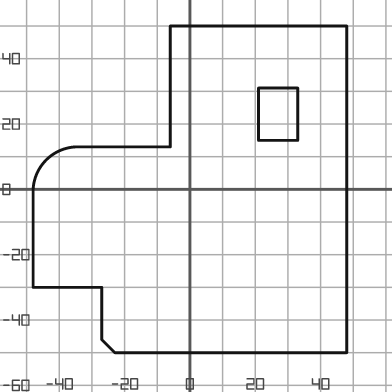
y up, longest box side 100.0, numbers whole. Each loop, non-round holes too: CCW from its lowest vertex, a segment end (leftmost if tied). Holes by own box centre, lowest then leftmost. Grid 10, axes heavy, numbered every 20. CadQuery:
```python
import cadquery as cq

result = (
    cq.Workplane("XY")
    .moveTo(-23.0, -50.0)
    .lineTo(48.0, -50.0)
    .lineTo(48.0, 50.0)
    .lineTo(-6.0, 50.0)
    .lineTo(-6.0, 13.0)
    .lineTo(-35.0, 13.0)
    .threePointArc((-44.0, 9.0), (-48.0, 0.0))
    .lineTo(-48.0, -30.0)
    .lineTo(-27.0, -30.0)
    .lineTo(-27.0, -46.0)
    .close()
    .moveTo(21.0, 15.0)
    .lineTo(33.0, 15.0)
    .lineTo(33.0, 31.0)
    .lineTo(21.0, 31.0)
    .close()
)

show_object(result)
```